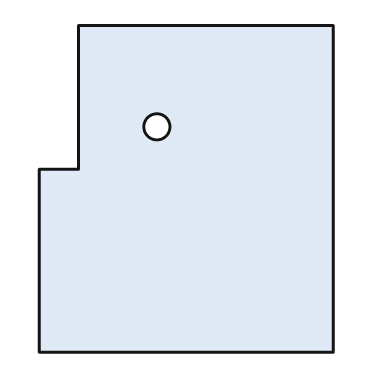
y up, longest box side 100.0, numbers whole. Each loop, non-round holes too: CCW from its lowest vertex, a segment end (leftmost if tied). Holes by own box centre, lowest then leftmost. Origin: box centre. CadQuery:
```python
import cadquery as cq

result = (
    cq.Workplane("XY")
    .moveTo(-45.0, -50.0)
    .lineTo(45.0, -50.0)
    .lineTo(45.0, 50.0)
    .lineTo(-33.0, 50.0)
    .lineTo(-33.0, 6.0)
    .lineTo(-45.0, 6.0)
    .close()
    .moveTo(-9.0, 19.0)
    .circle(4.0)
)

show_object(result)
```